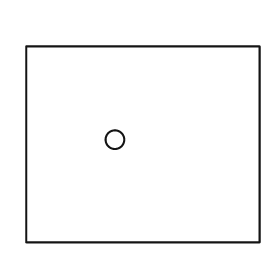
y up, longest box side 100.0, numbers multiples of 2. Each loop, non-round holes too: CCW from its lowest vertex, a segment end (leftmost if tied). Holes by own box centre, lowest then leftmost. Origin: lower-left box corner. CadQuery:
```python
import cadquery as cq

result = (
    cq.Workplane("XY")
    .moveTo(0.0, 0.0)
    .lineTo(100.0, 0.0)
    .lineTo(100.0, 84.0)
    .lineTo(0.0, 84.0)
    .close()
    .moveTo(38.0, 44.0)
    .circle(4.0)
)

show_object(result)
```